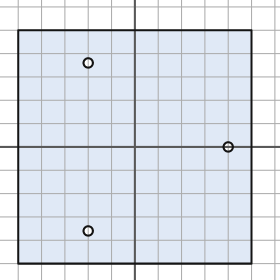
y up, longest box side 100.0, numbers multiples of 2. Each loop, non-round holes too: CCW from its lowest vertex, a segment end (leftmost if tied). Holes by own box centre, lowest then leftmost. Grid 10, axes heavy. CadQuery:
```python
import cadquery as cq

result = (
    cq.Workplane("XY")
    .moveTo(-50.0, -50.0)
    .lineTo(50.0, -50.0)
    .lineTo(50.0, 50.0)
    .lineTo(-50.0, 50.0)
    .close()
    .moveTo(-20.0, -36.0)
    .circle(2.0)
    .moveTo(40.0, 0.0)
    .circle(2.0)
    .moveTo(-20.0, 36.0)
    .circle(2.0)
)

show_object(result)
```